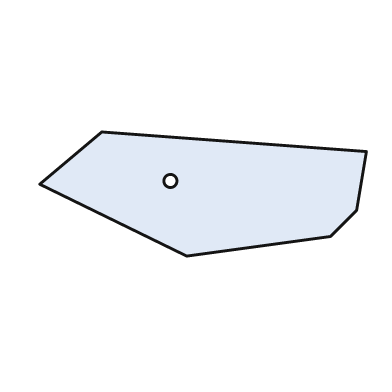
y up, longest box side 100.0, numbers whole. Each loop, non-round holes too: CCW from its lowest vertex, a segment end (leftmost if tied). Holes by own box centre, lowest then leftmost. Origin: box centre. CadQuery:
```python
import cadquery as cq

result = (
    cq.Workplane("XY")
    .moveTo(-5.0, -19.0)
    .lineTo(39.0, -13.0)
    .lineTo(47.0, -5.0)
    .lineTo(50.0, 13.0)
    .lineTo(-31.0, 19.0)
    .lineTo(-50.0, 3.0)
    .close()
    .moveTo(-10.0, 4.0)
    .circle(2.0)
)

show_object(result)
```